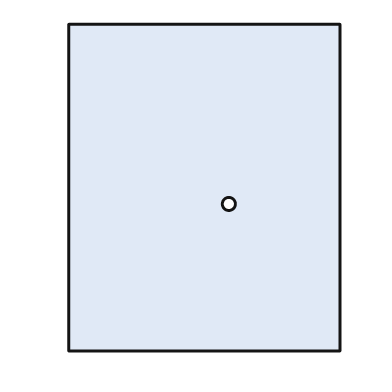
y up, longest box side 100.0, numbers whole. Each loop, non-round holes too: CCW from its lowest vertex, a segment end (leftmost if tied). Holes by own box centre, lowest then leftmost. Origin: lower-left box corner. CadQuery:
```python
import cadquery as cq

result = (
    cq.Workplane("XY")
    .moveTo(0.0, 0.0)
    .lineTo(83.0, 0.0)
    .lineTo(83.0, 100.0)
    .lineTo(0.0, 100.0)
    .close()
    .moveTo(49.0, 45.0)
    .circle(2.0)
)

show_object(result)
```